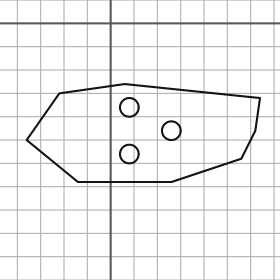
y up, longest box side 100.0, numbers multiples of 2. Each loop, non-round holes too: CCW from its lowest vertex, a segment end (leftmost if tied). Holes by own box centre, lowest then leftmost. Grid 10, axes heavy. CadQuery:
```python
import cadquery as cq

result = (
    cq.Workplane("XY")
    .moveTo(-14.0, -68.0)
    .lineTo(26.0, -68.0)
    .lineTo(56.0, -58.0)
    .lineTo(62.0, -46.0)
    .lineTo(64.0, -32.0)
    .lineTo(6.0, -26.0)
    .lineTo(-22.0, -30.0)
    .lineTo(-36.0, -50.0)
    .close()
    .moveTo(8.0, -56.0)
    .circle(4.0)
    .moveTo(26.0, -46.0)
    .circle(4.0)
    .moveTo(8.0, -36.0)
    .circle(4.0)
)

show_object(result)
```